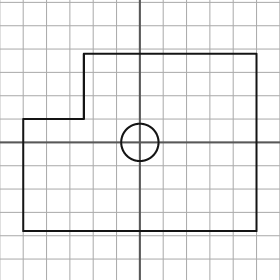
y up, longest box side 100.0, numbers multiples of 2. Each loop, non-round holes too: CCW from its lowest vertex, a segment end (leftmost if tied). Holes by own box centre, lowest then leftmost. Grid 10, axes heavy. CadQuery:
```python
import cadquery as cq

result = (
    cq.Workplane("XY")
    .moveTo(-50.0, -38.0)
    .lineTo(50.0, -38.0)
    .lineTo(50.0, 38.0)
    .lineTo(-24.0, 38.0)
    .lineTo(-24.0, 10.0)
    .lineTo(-50.0, 10.0)
    .close()
    .moveTo(0.0, 0.0)
    .circle(8.0)
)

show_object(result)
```